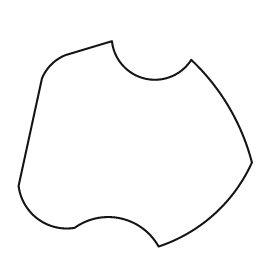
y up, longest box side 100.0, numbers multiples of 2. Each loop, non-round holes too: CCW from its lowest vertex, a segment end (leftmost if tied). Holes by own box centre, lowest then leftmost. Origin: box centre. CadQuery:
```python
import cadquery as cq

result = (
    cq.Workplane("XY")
    .moveTo(10.0, -44.0)
    .threePointArc((34.0, -30.0), (50.0, -8.0))
    .threePointArc((40.0, 16.0), (24.0, 36.0))
    .threePointArc((4.0, 28.0), (-10.0, 44.0))
    .lineTo(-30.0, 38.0)
    .threePointArc((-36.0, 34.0), (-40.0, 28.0))
    .lineTo(-50.0, -18.0)
    .threePointArc((-42.0, -32.0), (-26.0, -36.0))
    .threePointArc((-6.0, -32.0), (10.0, -44.0))
    .close()
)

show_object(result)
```